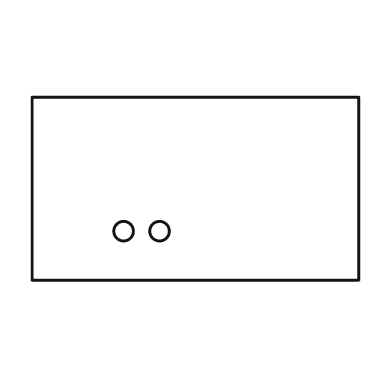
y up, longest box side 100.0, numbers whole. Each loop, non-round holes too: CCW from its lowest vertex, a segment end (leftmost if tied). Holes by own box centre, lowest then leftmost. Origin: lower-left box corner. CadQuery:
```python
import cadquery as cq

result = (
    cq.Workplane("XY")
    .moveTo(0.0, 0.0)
    .lineTo(100.0, 0.0)
    .lineTo(100.0, 56.0)
    .lineTo(0.0, 56.0)
    .close()
    .moveTo(28.0, 15.0)
    .circle(3.0)
    .moveTo(39.0, 15.0)
    .circle(3.0)
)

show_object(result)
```